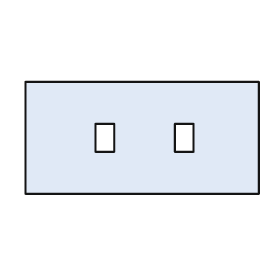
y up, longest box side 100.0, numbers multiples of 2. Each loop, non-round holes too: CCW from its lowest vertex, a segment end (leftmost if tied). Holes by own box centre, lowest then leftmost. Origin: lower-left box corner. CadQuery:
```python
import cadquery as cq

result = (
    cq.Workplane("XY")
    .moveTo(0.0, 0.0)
    .lineTo(100.0, 0.0)
    .lineTo(100.0, 48.0)
    .lineTo(0.0, 48.0)
    .close()
    .moveTo(30.0, 18.0)
    .lineTo(38.0, 18.0)
    .lineTo(38.0, 30.0)
    .lineTo(30.0, 30.0)
    .close()
    .moveTo(64.0, 18.0)
    .lineTo(72.0, 18.0)
    .lineTo(72.0, 30.0)
    .lineTo(64.0, 30.0)
    .close()
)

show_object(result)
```